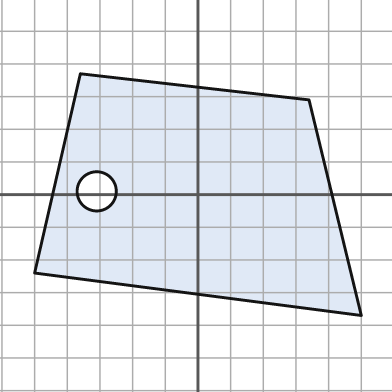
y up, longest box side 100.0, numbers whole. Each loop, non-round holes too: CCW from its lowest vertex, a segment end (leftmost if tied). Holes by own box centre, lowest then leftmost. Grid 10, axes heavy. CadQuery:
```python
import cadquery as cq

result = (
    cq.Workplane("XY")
    .moveTo(50.0, -37.0)
    .lineTo(34.0, 29.0)
    .lineTo(-36.0, 37.0)
    .lineTo(-50.0, -24.0)
    .close()
    .moveTo(-31.0, 1.0)
    .circle(6.0)
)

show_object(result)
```